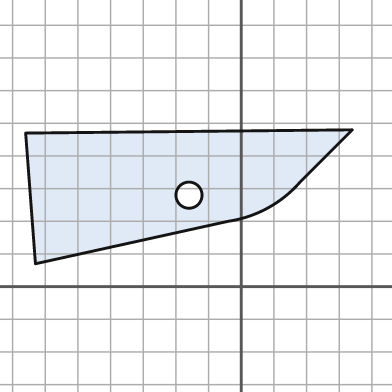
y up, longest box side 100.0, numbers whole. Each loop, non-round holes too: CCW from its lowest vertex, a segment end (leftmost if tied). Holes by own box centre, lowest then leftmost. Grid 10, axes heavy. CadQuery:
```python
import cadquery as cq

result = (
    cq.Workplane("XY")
    .moveTo(-63.0, 7.0)
    .lineTo(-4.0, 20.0)
    .threePointArc((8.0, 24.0), (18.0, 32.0))
    .lineTo(34.0, 48.0)
    .lineTo(-66.0, 47.0)
    .close()
    .moveTo(-16.0, 28.0)
    .circle(4.0)
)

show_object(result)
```